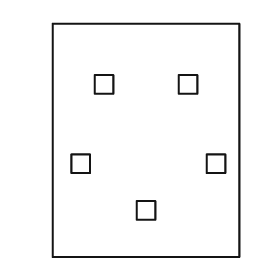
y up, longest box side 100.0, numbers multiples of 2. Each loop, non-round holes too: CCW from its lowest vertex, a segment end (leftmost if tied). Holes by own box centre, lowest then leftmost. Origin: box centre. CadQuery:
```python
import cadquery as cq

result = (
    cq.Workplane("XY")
    .moveTo(-40.0, -50.0)
    .lineTo(40.0, -50.0)
    .lineTo(40.0, 50.0)
    .lineTo(-40.0, 50.0)
    .close()
    .moveTo(-4.0, -34.0)
    .lineTo(4.0, -34.0)
    .lineTo(4.0, -26.0)
    .lineTo(-4.0, -26.0)
    .close()
    .moveTo(-32.0, -14.0)
    .lineTo(-24.0, -14.0)
    .lineTo(-24.0, -6.0)
    .lineTo(-32.0, -6.0)
    .close()
    .moveTo(26.0, -14.0)
    .lineTo(34.0, -14.0)
    .lineTo(34.0, -6.0)
    .lineTo(26.0, -6.0)
    .close()
    .moveTo(-22.0, 20.0)
    .lineTo(-14.0, 20.0)
    .lineTo(-14.0, 28.0)
    .lineTo(-22.0, 28.0)
    .close()
    .moveTo(14.0, 20.0)
    .lineTo(22.0, 20.0)
    .lineTo(22.0, 28.0)
    .lineTo(14.0, 28.0)
    .close()
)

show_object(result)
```